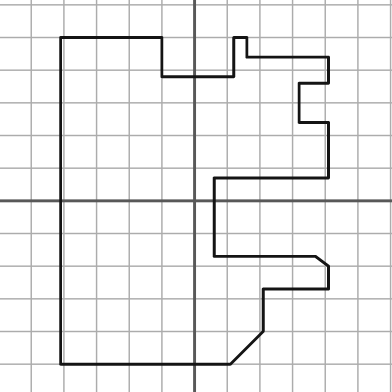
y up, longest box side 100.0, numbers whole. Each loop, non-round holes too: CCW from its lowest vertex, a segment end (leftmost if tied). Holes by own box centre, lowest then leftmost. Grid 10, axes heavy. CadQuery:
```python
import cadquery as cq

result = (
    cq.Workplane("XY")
    .moveTo(-41.0, -50.0)
    .lineTo(11.0, -50.0)
    .lineTo(21.0, -40.0)
    .lineTo(21.0, -27.0)
    .lineTo(41.0, -27.0)
    .lineTo(41.0, -20.0)
    .lineTo(37.0, -17.0)
    .lineTo(6.0, -17.0)
    .lineTo(6.0, 7.0)
    .lineTo(41.0, 7.0)
    .lineTo(41.0, 24.0)
    .lineTo(32.0, 24.0)
    .lineTo(32.0, 36.0)
    .lineTo(41.0, 36.0)
    .lineTo(41.0, 44.0)
    .lineTo(16.0, 44.0)
    .lineTo(16.0, 50.0)
    .lineTo(12.0, 50.0)
    .lineTo(12.0, 38.0)
    .lineTo(-10.0, 38.0)
    .lineTo(-10.0, 50.0)
    .lineTo(-41.0, 50.0)
    .close()
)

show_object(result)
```